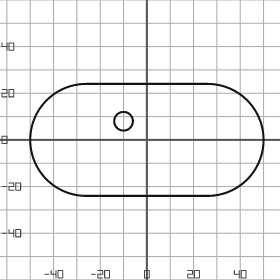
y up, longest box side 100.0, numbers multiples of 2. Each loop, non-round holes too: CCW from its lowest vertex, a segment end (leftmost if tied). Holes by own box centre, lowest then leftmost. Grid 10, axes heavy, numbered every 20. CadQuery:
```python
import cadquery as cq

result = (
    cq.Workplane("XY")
    .moveTo(-26.0, -24.0)
    .lineTo(26.0, -24.0)
    .threePointArc((50.0, 0.0), (26.0, 24.0))
    .lineTo(-26.0, 24.0)
    .threePointArc((-50.0, 0.0), (-26.0, -24.0))
    .close()
    .moveTo(-10.0, 8.0)
    .circle(4.0)
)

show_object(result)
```